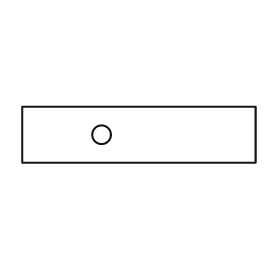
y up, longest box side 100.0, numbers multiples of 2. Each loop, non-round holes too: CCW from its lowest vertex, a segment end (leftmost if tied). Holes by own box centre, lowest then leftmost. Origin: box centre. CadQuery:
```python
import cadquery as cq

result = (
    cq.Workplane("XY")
    .moveTo(-50.0, -12.0)
    .lineTo(50.0, -12.0)
    .lineTo(50.0, 12.0)
    .lineTo(-50.0, 12.0)
    .close()
    .moveTo(-16.0, 0.0)
    .circle(4.0)
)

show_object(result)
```